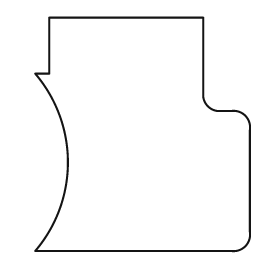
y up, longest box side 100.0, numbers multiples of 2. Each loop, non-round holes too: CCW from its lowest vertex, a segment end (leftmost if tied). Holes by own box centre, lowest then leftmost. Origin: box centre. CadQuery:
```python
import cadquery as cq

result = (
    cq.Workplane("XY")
    .moveTo(-46.0, -50.0)
    .lineTo(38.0, -50.0)
    .threePointArc((44.0, -48.0), (46.0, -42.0))
    .lineTo(46.0, 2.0)
    .threePointArc((44.0, 8.0), (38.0, 10.0))
    .lineTo(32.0, 10.0)
    .threePointArc((28.0, 12.0), (26.0, 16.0))
    .lineTo(26.0, 50.0)
    .lineTo(-40.0, 50.0)
    .lineTo(-40.0, 26.0)
    .lineTo(-46.0, 26.0)
    .threePointArc((-32.0, -12.0), (-46.0, -50.0))
    .close()
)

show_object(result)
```